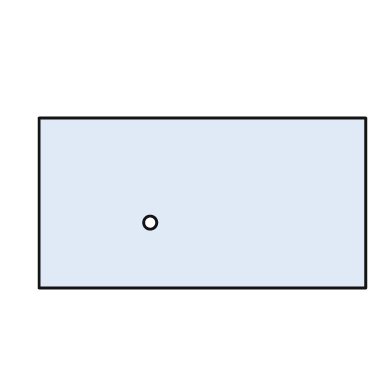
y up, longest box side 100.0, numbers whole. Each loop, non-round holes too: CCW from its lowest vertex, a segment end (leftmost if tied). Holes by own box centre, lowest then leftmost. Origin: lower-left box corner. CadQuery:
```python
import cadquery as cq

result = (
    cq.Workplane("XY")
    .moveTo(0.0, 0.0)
    .lineTo(100.0, 0.0)
    .lineTo(100.0, 52.0)
    .lineTo(0.0, 52.0)
    .close()
    .moveTo(34.0, 20.0)
    .circle(2.0)
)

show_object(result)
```